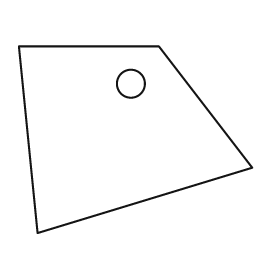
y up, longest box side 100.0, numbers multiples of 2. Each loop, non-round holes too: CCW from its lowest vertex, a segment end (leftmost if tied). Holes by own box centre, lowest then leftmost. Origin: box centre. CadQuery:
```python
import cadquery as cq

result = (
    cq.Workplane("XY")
    .moveTo(-42.0, -40.0)
    .lineTo(50.0, -12.0)
    .lineTo(10.0, 40.0)
    .lineTo(-50.0, 40.0)
    .close()
    .moveTo(-2.0, 24.0)
    .circle(6.0)
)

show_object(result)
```